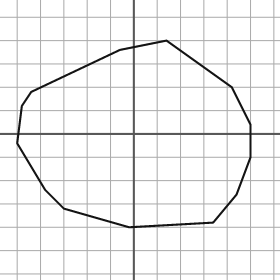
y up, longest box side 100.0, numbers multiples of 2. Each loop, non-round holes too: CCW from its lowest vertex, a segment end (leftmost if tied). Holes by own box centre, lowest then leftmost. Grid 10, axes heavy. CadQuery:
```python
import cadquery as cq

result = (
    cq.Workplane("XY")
    .moveTo(-2.0, -40.0)
    .lineTo(34.0, -38.0)
    .lineTo(44.0, -26.0)
    .lineTo(50.0, -10.0)
    .lineTo(50.0, 4.0)
    .lineTo(42.0, 20.0)
    .lineTo(14.0, 40.0)
    .lineTo(-6.0, 36.0)
    .lineTo(-44.0, 18.0)
    .lineTo(-48.0, 12.0)
    .lineTo(-50.0, -4.0)
    .lineTo(-38.0, -24.0)
    .lineTo(-30.0, -32.0)
    .close()
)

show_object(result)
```